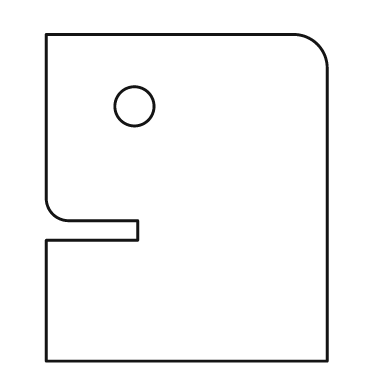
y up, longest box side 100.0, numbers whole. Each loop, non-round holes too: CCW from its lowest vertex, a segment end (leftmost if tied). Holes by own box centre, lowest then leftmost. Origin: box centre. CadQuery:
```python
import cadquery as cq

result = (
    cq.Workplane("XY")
    .moveTo(-43.0, -50.0)
    .lineTo(43.0, -50.0)
    .lineTo(43.0, 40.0)
    .threePointArc((40.0, 47.0), (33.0, 50.0))
    .lineTo(-43.0, 50.0)
    .lineTo(-43.0, 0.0)
    .threePointArc((-41.0, -5.0), (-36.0, -7.0))
    .lineTo(-15.0, -7.0)
    .lineTo(-15.0, -13.0)
    .lineTo(-43.0, -13.0)
    .close()
    .moveTo(-16.0, 28.0)
    .circle(6.0)
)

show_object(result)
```